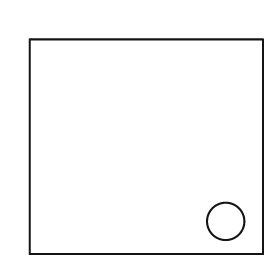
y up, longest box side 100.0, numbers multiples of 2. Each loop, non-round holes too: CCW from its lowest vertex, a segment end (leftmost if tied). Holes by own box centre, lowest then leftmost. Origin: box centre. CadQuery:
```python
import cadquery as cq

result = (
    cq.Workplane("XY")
    .moveTo(-50.0, -46.0)
    .lineTo(50.0, -46.0)
    .lineTo(50.0, 46.0)
    .lineTo(-50.0, 46.0)
    .close()
    .moveTo(34.0, -32.0)
    .circle(8.0)
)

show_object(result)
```